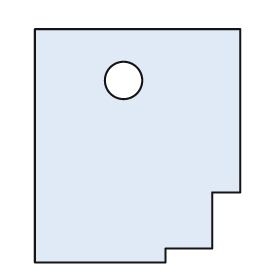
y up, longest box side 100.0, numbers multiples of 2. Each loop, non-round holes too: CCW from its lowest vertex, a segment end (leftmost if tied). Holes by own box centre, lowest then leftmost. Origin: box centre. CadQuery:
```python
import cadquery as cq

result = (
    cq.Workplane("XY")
    .moveTo(-44.0, -50.0)
    .lineTo(12.0, -50.0)
    .lineTo(12.0, -44.0)
    .lineTo(32.0, -44.0)
    .lineTo(32.0, -20.0)
    .lineTo(44.0, -20.0)
    .lineTo(44.0, 50.0)
    .lineTo(-44.0, 50.0)
    .close()
    .moveTo(-6.0, 28.0)
    .circle(8.0)
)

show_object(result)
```